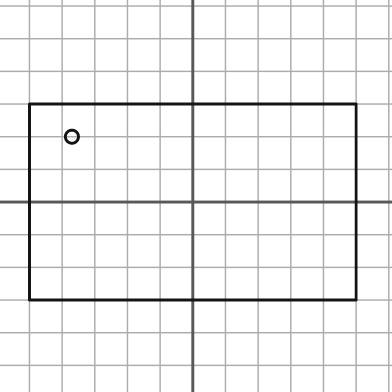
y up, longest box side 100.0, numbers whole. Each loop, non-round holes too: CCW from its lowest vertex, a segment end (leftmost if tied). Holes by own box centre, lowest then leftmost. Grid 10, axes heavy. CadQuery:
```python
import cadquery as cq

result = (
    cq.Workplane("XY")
    .moveTo(-50.0, -30.0)
    .lineTo(50.0, -30.0)
    .lineTo(50.0, 30.0)
    .lineTo(-50.0, 30.0)
    .close()
    .moveTo(-37.0, 20.0)
    .circle(2.0)
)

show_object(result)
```